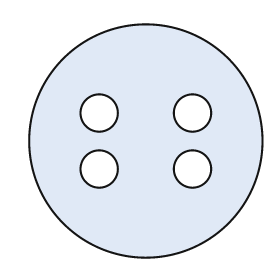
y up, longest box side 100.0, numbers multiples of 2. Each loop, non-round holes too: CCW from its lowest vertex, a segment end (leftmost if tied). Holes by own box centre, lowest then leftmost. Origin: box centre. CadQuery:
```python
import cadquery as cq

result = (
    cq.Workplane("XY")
    .moveTo(0.0, 0.0)
    .circle(50.0)
    .moveTo(-20.0, -12.0)
    .circle(8.0)
    .moveTo(20.0, -12.0)
    .circle(8.0)
    .moveTo(-20.0, 12.0)
    .circle(8.0)
    .moveTo(20.0, 12.0)
    .circle(8.0)
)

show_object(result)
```